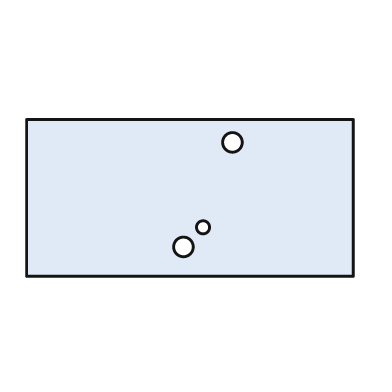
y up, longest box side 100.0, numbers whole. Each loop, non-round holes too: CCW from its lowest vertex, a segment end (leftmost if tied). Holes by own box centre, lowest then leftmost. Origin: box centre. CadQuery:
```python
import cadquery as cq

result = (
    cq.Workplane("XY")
    .moveTo(-50.0, -24.0)
    .lineTo(50.0, -24.0)
    .lineTo(50.0, 24.0)
    .lineTo(-50.0, 24.0)
    .close()
    .moveTo(-2.0, -15.0)
    .circle(3.0)
    .moveTo(4.0, -9.0)
    .circle(2.0)
    .moveTo(13.0, 17.0)
    .circle(3.0)
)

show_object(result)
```